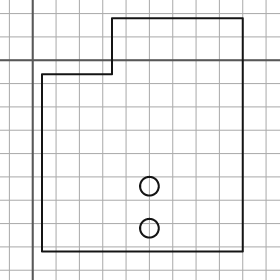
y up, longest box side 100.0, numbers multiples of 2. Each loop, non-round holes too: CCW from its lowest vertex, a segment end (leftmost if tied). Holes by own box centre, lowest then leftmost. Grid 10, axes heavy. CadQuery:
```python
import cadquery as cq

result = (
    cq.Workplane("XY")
    .moveTo(4.0, -82.0)
    .lineTo(90.0, -82.0)
    .lineTo(90.0, 18.0)
    .lineTo(34.0, 18.0)
    .lineTo(34.0, -6.0)
    .lineTo(4.0, -6.0)
    .close()
    .moveTo(50.0, -72.0)
    .circle(4.0)
    .moveTo(50.0, -54.0)
    .circle(4.0)
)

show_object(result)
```